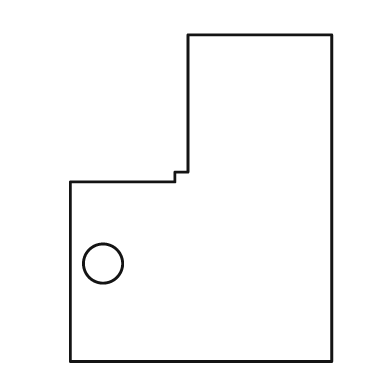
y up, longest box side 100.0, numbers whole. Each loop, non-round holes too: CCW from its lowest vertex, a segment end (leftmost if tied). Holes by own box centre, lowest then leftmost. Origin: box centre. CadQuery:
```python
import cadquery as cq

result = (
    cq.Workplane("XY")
    .moveTo(-40.0, -50.0)
    .lineTo(40.0, -50.0)
    .lineTo(40.0, 50.0)
    .lineTo(-4.0, 50.0)
    .lineTo(-4.0, 8.0)
    .lineTo(-8.0, 8.0)
    .lineTo(-8.0, 5.0)
    .lineTo(-40.0, 5.0)
    .close()
    .moveTo(-30.0, -20.0)
    .circle(6.0)
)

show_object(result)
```